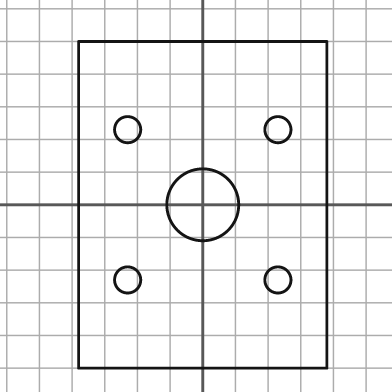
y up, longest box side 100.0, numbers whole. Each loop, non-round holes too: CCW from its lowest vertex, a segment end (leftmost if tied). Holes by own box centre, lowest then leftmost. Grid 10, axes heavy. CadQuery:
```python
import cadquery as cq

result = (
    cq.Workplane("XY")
    .moveTo(-38.0, -50.0)
    .lineTo(38.0, -50.0)
    .lineTo(38.0, 50.0)
    .lineTo(-38.0, 50.0)
    .close()
    .moveTo(-23.0, -23.0)
    .circle(4.0)
    .moveTo(23.0, -23.0)
    .circle(4.0)
    .moveTo(0.0, 0.0)
    .circle(11.0)
    .moveTo(-23.0, 23.0)
    .circle(4.0)
    .moveTo(23.0, 23.0)
    .circle(4.0)
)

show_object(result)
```